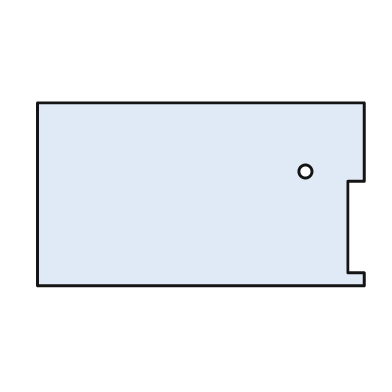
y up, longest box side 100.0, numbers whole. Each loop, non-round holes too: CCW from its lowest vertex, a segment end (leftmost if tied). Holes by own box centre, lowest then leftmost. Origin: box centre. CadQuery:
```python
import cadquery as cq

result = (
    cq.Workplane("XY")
    .moveTo(-50.0, -28.0)
    .lineTo(50.0, -28.0)
    .lineTo(50.0, -24.0)
    .lineTo(45.0, -24.0)
    .lineTo(45.0, 4.0)
    .lineTo(50.0, 4.0)
    .lineTo(50.0, 28.0)
    .lineTo(-50.0, 28.0)
    .close()
    .moveTo(32.0, 7.0)
    .circle(2.0)
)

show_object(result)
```